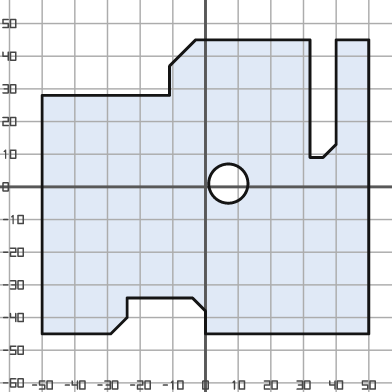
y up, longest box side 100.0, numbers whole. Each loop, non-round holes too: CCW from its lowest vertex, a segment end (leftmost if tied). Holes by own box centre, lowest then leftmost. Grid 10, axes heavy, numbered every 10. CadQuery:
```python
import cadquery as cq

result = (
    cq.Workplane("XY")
    .moveTo(-50.0, -45.0)
    .lineTo(-29.0, -45.0)
    .lineTo(-24.0, -40.0)
    .lineTo(-24.0, -34.0)
    .lineTo(-4.0, -34.0)
    .lineTo(0.0, -38.0)
    .lineTo(0.0, -45.0)
    .lineTo(50.0, -45.0)
    .lineTo(50.0, 45.0)
    .lineTo(40.0, 45.0)
    .lineTo(40.0, 13.0)
    .lineTo(36.0, 9.0)
    .lineTo(32.0, 9.0)
    .lineTo(32.0, 45.0)
    .lineTo(-3.0, 45.0)
    .lineTo(-11.0, 37.0)
    .lineTo(-11.0, 28.0)
    .lineTo(-50.0, 28.0)
    .close()
    .moveTo(7.0, 1.0)
    .circle(6.0)
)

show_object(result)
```